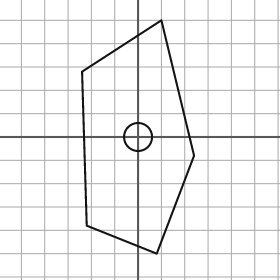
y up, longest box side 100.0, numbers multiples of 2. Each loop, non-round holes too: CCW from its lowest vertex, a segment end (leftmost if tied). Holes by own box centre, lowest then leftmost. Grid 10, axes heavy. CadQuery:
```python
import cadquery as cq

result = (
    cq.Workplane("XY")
    .moveTo(8.0, -50.0)
    .lineTo(24.0, -8.0)
    .lineTo(10.0, 50.0)
    .lineTo(-24.0, 28.0)
    .lineTo(-22.0, -38.0)
    .close()
    .moveTo(0.0, 0.0)
    .circle(6.0)
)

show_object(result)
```